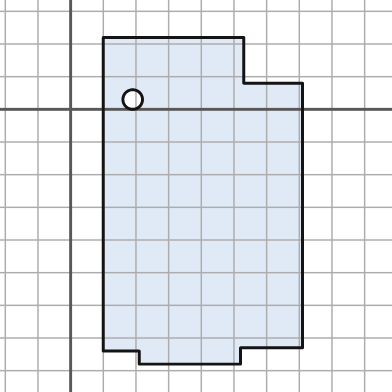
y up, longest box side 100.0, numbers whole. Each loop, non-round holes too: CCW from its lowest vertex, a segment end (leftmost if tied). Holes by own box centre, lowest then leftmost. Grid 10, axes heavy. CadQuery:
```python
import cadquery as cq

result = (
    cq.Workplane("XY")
    .moveTo(21.0, -78.0)
    .lineTo(52.0, -78.0)
    .lineTo(52.0, -73.0)
    .lineTo(71.0, -73.0)
    .lineTo(71.0, 8.0)
    .lineTo(53.0, 8.0)
    .lineTo(53.0, 22.0)
    .lineTo(10.0, 22.0)
    .lineTo(10.0, -74.0)
    .lineTo(21.0, -74.0)
    .close()
    .moveTo(19.0, 3.0)
    .circle(3.0)
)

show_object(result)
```